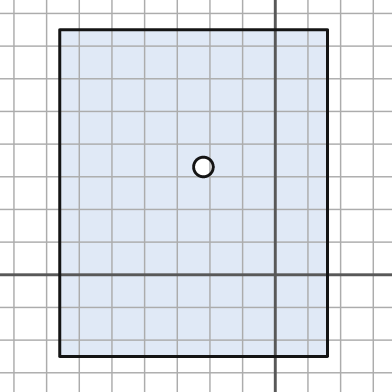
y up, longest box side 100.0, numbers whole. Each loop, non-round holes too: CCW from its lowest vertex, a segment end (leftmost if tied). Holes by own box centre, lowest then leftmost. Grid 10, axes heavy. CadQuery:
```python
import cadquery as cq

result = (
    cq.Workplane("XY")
    .moveTo(-66.0, -25.0)
    .lineTo(16.0, -25.0)
    .lineTo(16.0, 75.0)
    .lineTo(-66.0, 75.0)
    .close()
    .moveTo(-22.0, 33.0)
    .circle(3.0)
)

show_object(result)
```